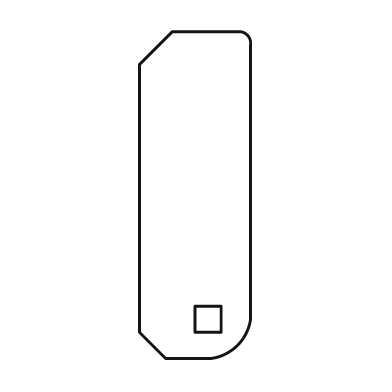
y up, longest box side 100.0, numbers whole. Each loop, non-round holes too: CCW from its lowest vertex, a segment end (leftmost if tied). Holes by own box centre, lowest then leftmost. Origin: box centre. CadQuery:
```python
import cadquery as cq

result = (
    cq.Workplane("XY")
    .moveTo(-9.0, -50.0)
    .lineTo(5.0, -50.0)
    .threePointArc((13.0, -46.0), (17.0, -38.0))
    .lineTo(17.0, 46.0)
    .threePointArc((16.0, 49.0), (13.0, 50.0))
    .lineTo(-7.0, 50.0)
    .lineTo(-17.0, 40.0)
    .lineTo(-17.0, -42.0)
    .close()
    .moveTo(0.0, -42.0)
    .lineTo(8.0, -42.0)
    .lineTo(8.0, -34.0)
    .lineTo(0.0, -34.0)
    .close()
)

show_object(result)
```